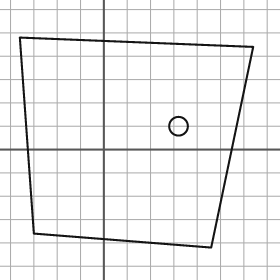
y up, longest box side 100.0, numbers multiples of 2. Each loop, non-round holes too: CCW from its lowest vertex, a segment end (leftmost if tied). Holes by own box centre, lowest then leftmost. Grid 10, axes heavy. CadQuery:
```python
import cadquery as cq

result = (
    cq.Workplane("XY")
    .moveTo(46.0, -42.0)
    .lineTo(64.0, 44.0)
    .lineTo(-36.0, 48.0)
    .lineTo(-30.0, -36.0)
    .close()
    .moveTo(32.0, 10.0)
    .circle(4.0)
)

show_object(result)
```